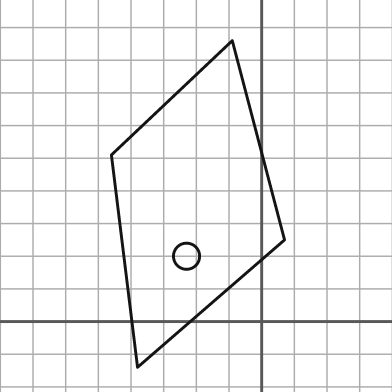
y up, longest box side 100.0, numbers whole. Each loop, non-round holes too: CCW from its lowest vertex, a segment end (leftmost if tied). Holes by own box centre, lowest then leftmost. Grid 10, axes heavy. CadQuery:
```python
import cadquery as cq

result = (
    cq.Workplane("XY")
    .moveTo(-38.0, -14.0)
    .lineTo(7.0, 25.0)
    .lineTo(-9.0, 86.0)
    .lineTo(-46.0, 51.0)
    .close()
    .moveTo(-23.0, 20.0)
    .circle(4.0)
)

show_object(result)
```